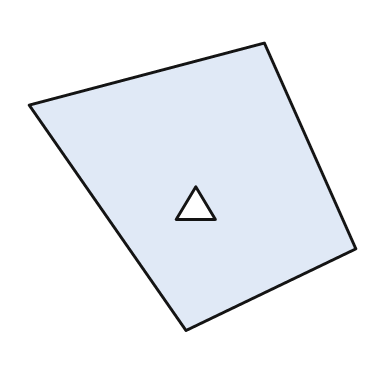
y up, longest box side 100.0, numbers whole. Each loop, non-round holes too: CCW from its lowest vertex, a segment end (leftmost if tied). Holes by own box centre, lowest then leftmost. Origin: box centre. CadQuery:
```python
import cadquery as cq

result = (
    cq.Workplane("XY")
    .moveTo(-2.0, -44.0)
    .lineTo(50.0, -19.0)
    .lineTo(22.0, 44.0)
    .lineTo(-50.0, 25.0)
    .close()
    .moveTo(-5.0, -10.0)
    .lineTo(7.0, -10.0)
    .lineTo(1.0, 0.0)
    .close()
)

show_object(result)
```